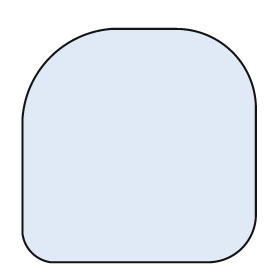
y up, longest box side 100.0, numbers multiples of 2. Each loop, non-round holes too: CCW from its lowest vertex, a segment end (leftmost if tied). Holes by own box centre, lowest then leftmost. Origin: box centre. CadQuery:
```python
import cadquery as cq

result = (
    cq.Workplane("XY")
    .moveTo(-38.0, -50.0)
    .lineTo(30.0, -50.0)
    .threePointArc((44.0, -44.0), (50.0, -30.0))
    .lineTo(50.0, 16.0)
    .threePointArc((40.0, 40.0), (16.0, 50.0))
    .lineTo(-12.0, 50.0)
    .threePointArc((-38.0, 38.0), (-50.0, 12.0))
    .lineTo(-50.0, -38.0)
    .threePointArc((-46.0, -46.0), (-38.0, -50.0))
    .close()
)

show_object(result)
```